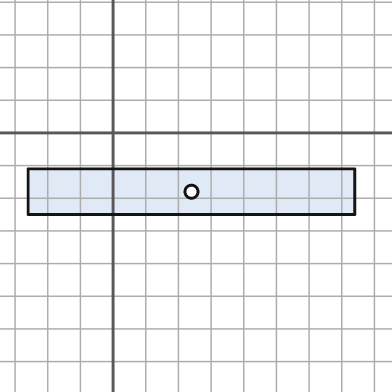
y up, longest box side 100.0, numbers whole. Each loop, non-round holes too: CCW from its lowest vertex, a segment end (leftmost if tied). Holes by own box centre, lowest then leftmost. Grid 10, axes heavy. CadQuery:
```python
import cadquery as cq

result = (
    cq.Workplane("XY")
    .moveTo(-26.0, -25.0)
    .lineTo(74.0, -25.0)
    .lineTo(74.0, -11.0)
    .lineTo(-26.0, -11.0)
    .close()
    .moveTo(24.0, -18.0)
    .circle(2.0)
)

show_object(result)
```